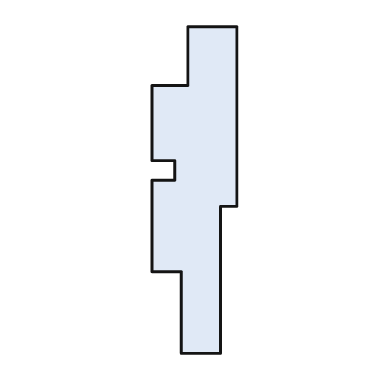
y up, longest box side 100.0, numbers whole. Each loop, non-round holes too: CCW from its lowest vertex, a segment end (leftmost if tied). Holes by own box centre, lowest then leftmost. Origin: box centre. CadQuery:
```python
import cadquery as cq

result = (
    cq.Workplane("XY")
    .moveTo(-4.0, -50.0)
    .lineTo(8.0, -50.0)
    .lineTo(8.0, -5.0)
    .lineTo(13.0, -5.0)
    .lineTo(13.0, 50.0)
    .lineTo(-2.0, 50.0)
    .lineTo(-2.0, 32.0)
    .lineTo(-13.0, 32.0)
    .lineTo(-13.0, 9.0)
    .lineTo(-6.0, 9.0)
    .lineTo(-6.0, 3.0)
    .lineTo(-13.0, 3.0)
    .lineTo(-13.0, -25.0)
    .lineTo(-4.0, -25.0)
    .close()
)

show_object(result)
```